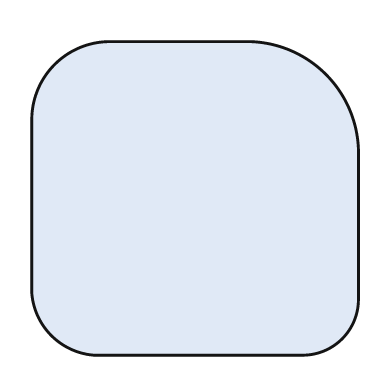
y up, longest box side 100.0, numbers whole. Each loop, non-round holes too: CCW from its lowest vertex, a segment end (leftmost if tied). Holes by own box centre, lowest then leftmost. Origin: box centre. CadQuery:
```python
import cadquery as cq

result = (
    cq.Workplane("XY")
    .moveTo(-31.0, -48.0)
    .lineTo(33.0, -48.0)
    .threePointArc((45.0, -43.0), (50.0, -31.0))
    .lineTo(50.0, 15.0)
    .threePointArc((40.0, 38.0), (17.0, 48.0))
    .lineTo(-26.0, 48.0)
    .threePointArc((-43.0, 41.0), (-50.0, 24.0))
    .lineTo(-50.0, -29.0)
    .threePointArc((-44.0, -42.0), (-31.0, -48.0))
    .close()
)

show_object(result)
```